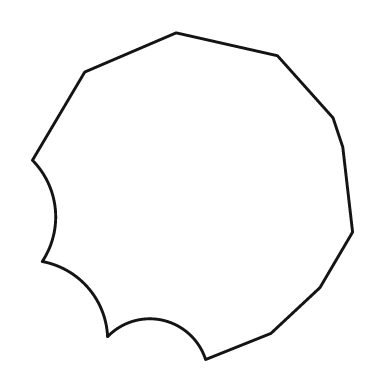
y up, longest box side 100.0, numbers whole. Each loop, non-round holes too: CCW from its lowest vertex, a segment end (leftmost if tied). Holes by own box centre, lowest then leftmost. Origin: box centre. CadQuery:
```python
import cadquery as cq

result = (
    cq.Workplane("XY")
    .moveTo(4.0, -50.0)
    .lineTo(24.0, -42.0)
    .lineTo(39.0, -28.0)
    .lineTo(49.0, -11.0)
    .lineTo(46.0, 15.0)
    .lineTo(43.0, 24.0)
    .lineTo(26.0, 43.0)
    .lineTo(-5.0, 50.0)
    .lineTo(-33.0, 38.0)
    .lineTo(-49.0, 11.0)
    .threePointArc((-42.0, -4.0), (-46.0, -20.0))
    .threePointArc((-32.0, -28.0), (-26.0, -43.0))
    .threePointArc((-9.0, -38.0), (4.0, -50.0))
    .close()
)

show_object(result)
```